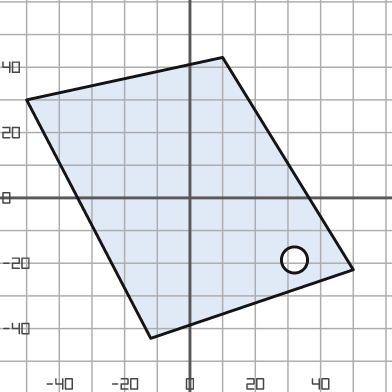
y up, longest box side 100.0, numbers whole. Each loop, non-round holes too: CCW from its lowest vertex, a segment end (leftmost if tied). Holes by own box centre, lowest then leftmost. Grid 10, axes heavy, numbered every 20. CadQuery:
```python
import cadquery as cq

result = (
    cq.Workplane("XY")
    .moveTo(-12.0, -43.0)
    .lineTo(50.0, -22.0)
    .lineTo(10.0, 43.0)
    .lineTo(-50.0, 30.0)
    .close()
    .moveTo(32.0, -19.0)
    .circle(4.0)
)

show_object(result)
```